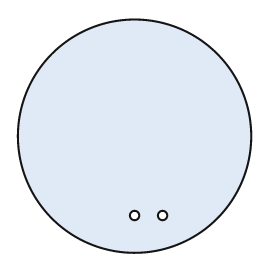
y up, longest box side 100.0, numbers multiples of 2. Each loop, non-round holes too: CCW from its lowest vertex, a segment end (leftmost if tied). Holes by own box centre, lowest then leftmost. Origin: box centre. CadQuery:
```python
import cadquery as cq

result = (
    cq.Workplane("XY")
    .moveTo(0.0, 0.0)
    .circle(50.0)
    .moveTo(0.0, -34.0)
    .circle(2.0)
    .moveTo(12.0, -34.0)
    .circle(2.0)
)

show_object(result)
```